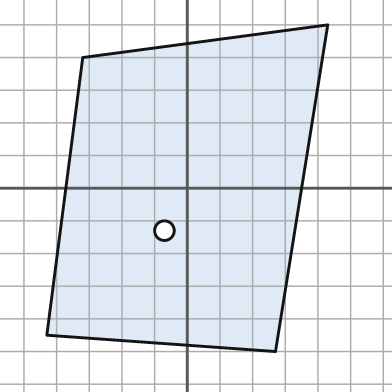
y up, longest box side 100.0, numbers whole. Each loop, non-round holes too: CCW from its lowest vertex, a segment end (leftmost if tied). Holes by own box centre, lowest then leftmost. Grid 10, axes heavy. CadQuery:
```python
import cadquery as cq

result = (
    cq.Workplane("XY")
    .moveTo(27.0, -50.0)
    .lineTo(43.0, 50.0)
    .lineTo(-32.0, 40.0)
    .lineTo(-43.0, -45.0)
    .close()
    .moveTo(-7.0, -13.0)
    .circle(3.0)
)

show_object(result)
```